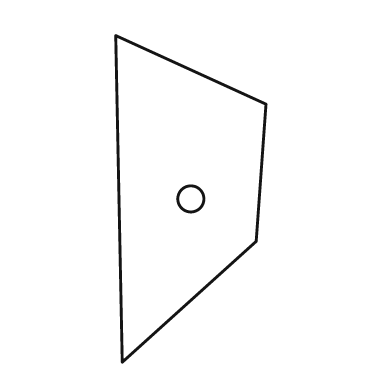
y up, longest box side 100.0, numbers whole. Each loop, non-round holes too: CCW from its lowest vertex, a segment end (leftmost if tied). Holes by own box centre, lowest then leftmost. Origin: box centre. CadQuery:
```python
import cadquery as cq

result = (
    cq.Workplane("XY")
    .moveTo(-21.0, -50.0)
    .lineTo(20.0, -13.0)
    .lineTo(23.0, 29.0)
    .lineTo(-23.0, 50.0)
    .close()
    .moveTo(0.0, 0.0)
    .circle(4.0)
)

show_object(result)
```